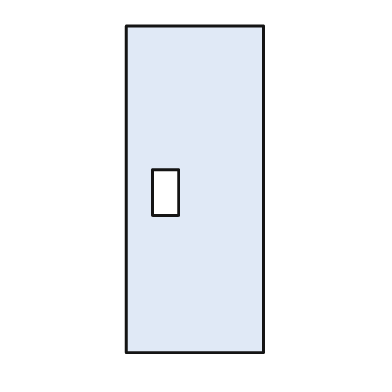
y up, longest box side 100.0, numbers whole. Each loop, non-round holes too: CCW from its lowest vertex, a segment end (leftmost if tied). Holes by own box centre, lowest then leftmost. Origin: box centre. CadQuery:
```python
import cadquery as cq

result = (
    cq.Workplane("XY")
    .moveTo(-21.0, -50.0)
    .lineTo(21.0, -50.0)
    .lineTo(21.0, 50.0)
    .lineTo(-21.0, 50.0)
    .close()
    .moveTo(-13.0, -8.0)
    .lineTo(-5.0, -8.0)
    .lineTo(-5.0, 6.0)
    .lineTo(-13.0, 6.0)
    .close()
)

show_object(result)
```